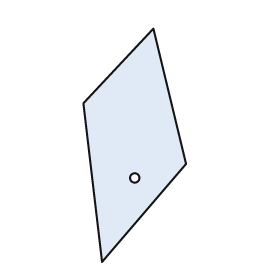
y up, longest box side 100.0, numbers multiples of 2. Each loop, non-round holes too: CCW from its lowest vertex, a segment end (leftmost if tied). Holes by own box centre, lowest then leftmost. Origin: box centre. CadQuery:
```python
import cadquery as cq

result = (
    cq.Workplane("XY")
    .moveTo(-14.0, -50.0)
    .lineTo(22.0, -8.0)
    .lineTo(8.0, 50.0)
    .lineTo(-22.0, 18.0)
    .close()
    .moveTo(0.0, -14.0)
    .circle(2.0)
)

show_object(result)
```